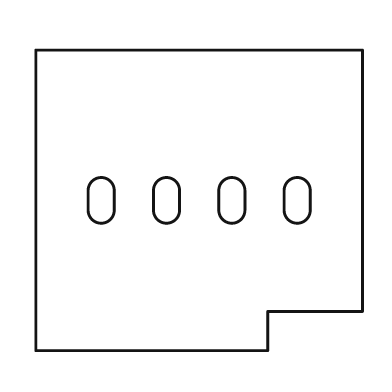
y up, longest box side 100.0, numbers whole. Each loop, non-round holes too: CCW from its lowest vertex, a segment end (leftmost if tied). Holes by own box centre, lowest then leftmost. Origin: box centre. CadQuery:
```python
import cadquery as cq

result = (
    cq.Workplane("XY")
    .moveTo(-50.0, -46.0)
    .lineTo(21.0, -46.0)
    .lineTo(21.0, -34.0)
    .lineTo(50.0, -34.0)
    .lineTo(50.0, 46.0)
    .lineTo(-50.0, 46.0)
    .close()
    .moveTo(-34.0, -3.0)
    .threePointArc((-30.0, -7.0), (-26.0, -3.0))
    .lineTo(-26.0, 3.0)
    .threePointArc((-30.0, 7.0), (-34.0, 3.0))
    .close()
    .moveTo(-14.0, -3.0)
    .threePointArc((-10.0, -7.0), (-6.0, -3.0))
    .lineTo(-6.0, 3.0)
    .threePointArc((-10.0, 7.0), (-14.0, 3.0))
    .close()
    .moveTo(6.0, -3.0)
    .threePointArc((10.0, -7.0), (14.0, -3.0))
    .lineTo(14.0, 3.0)
    .threePointArc((10.0, 7.0), (6.0, 3.0))
    .close()
    .moveTo(26.0, -3.0)
    .threePointArc((30.0, -7.0), (34.0, -3.0))
    .lineTo(34.0, 3.0)
    .threePointArc((30.0, 7.0), (26.0, 3.0))
    .close()
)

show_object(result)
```